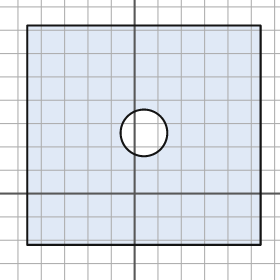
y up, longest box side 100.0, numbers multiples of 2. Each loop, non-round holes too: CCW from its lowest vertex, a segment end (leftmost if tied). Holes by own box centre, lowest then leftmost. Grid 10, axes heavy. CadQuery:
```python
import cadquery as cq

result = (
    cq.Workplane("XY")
    .moveTo(-46.0, -22.0)
    .lineTo(54.0, -22.0)
    .lineTo(54.0, 72.0)
    .lineTo(-46.0, 72.0)
    .close()
    .moveTo(4.0, 26.0)
    .circle(10.0)
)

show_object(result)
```